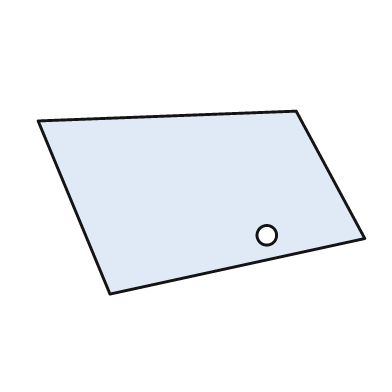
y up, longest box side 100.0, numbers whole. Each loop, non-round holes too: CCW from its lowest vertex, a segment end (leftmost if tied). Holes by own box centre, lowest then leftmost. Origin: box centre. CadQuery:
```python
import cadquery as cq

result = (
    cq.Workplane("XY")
    .moveTo(-28.0, -28.0)
    .lineTo(50.0, -11.0)
    .lineTo(29.0, 28.0)
    .lineTo(-50.0, 25.0)
    .close()
    .moveTo(20.0, -10.0)
    .circle(3.0)
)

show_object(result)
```